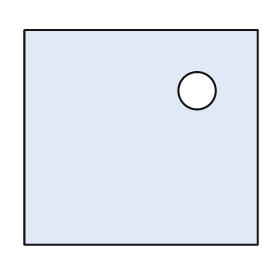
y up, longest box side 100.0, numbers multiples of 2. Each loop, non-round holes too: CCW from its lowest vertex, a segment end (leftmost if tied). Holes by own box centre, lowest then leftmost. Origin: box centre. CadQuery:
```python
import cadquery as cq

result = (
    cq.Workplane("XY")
    .moveTo(-50.0, -46.0)
    .lineTo(50.0, -46.0)
    .lineTo(50.0, 46.0)
    .lineTo(-50.0, 46.0)
    .close()
    .moveTo(24.0, 20.0)
    .circle(8.0)
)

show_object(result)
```